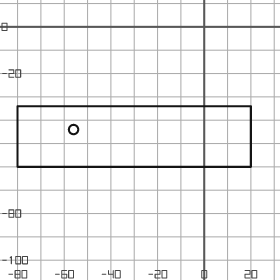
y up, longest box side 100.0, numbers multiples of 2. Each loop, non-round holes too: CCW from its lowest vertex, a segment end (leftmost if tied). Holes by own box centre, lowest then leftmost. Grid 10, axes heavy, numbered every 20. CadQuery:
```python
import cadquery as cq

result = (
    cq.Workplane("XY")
    .moveTo(-80.0, -60.0)
    .lineTo(20.0, -60.0)
    .lineTo(20.0, -34.0)
    .lineTo(-80.0, -34.0)
    .close()
    .moveTo(-56.0, -44.0)
    .circle(2.0)
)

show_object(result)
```